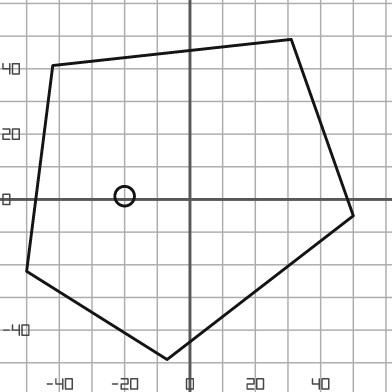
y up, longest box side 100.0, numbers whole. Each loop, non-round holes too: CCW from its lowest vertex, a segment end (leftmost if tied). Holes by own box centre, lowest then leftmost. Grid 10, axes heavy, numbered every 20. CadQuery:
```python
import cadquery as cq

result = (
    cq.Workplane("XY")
    .moveTo(-7.0, -49.0)
    .lineTo(50.0, -5.0)
    .lineTo(31.0, 49.0)
    .lineTo(-42.0, 41.0)
    .lineTo(-50.0, -22.0)
    .close()
    .moveTo(-20.0, 1.0)
    .circle(3.0)
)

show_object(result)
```